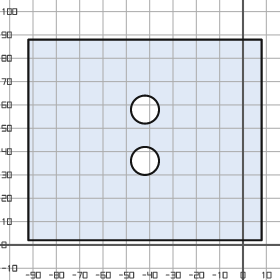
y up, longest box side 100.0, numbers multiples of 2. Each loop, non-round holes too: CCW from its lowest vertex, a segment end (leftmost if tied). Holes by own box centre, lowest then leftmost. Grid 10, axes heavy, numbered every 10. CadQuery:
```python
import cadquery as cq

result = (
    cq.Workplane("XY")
    .moveTo(-92.0, 2.0)
    .lineTo(8.0, 2.0)
    .lineTo(8.0, 88.0)
    .lineTo(-92.0, 88.0)
    .close()
    .moveTo(-42.0, 36.0)
    .circle(6.0)
    .moveTo(-42.0, 58.0)
    .circle(6.0)
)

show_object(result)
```